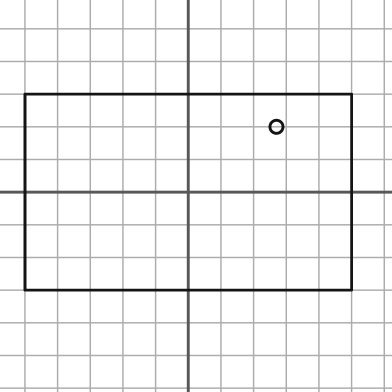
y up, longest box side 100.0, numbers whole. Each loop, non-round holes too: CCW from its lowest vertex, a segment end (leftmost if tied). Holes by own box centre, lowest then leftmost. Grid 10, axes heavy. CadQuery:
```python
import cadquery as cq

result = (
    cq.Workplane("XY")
    .moveTo(-50.0, -30.0)
    .lineTo(50.0, -30.0)
    .lineTo(50.0, 30.0)
    .lineTo(-50.0, 30.0)
    .close()
    .moveTo(27.0, 20.0)
    .circle(2.0)
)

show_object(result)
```